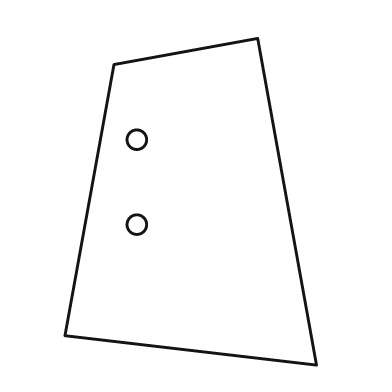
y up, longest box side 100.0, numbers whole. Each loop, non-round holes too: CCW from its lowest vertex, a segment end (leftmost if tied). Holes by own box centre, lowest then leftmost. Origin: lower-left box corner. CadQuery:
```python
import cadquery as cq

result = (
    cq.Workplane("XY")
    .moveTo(77.0, 0.0)
    .lineTo(59.0, 100.0)
    .lineTo(15.0, 92.0)
    .lineTo(0.0, 9.0)
    .close()
    .moveTo(22.0, 43.0)
    .circle(3.0)
    .moveTo(22.0, 69.0)
    .circle(3.0)
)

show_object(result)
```